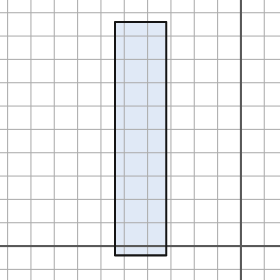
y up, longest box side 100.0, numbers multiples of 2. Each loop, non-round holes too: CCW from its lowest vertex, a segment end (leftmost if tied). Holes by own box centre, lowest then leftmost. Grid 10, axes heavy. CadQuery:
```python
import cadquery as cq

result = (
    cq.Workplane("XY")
    .moveTo(-54.0, -4.0)
    .lineTo(-32.0, -4.0)
    .lineTo(-32.0, 96.0)
    .lineTo(-54.0, 96.0)
    .close()
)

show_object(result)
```